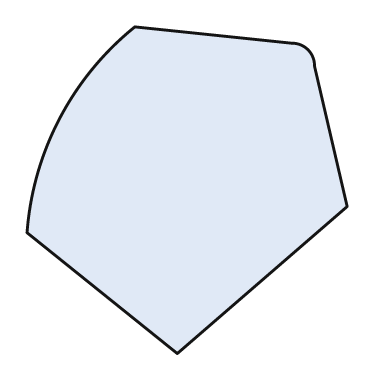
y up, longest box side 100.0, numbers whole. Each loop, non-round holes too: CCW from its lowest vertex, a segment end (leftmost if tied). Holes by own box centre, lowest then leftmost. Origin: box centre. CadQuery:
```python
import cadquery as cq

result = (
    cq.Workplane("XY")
    .moveTo(-3.0, -50.0)
    .lineTo(49.0, -5.0)
    .lineTo(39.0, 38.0)
    .threePointArc((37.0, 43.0), (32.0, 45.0))
    .lineTo(-16.0, 50.0)
    .threePointArc((-39.0, 22.0), (-49.0, -13.0))
    .close()
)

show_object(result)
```